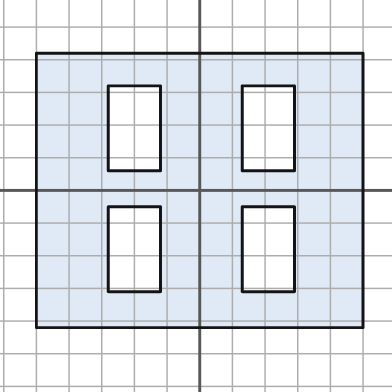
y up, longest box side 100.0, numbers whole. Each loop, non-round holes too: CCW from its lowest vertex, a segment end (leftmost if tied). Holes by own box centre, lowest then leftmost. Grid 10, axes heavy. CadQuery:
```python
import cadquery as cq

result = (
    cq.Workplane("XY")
    .moveTo(-50.0, -42.0)
    .lineTo(50.0, -42.0)
    .lineTo(50.0, 42.0)
    .lineTo(-50.0, 42.0)
    .close()
    .moveTo(-28.0, -31.0)
    .lineTo(-12.0, -31.0)
    .lineTo(-12.0, -5.0)
    .lineTo(-28.0, -5.0)
    .close()
    .moveTo(13.0, -31.0)
    .lineTo(29.0, -31.0)
    .lineTo(29.0, -5.0)
    .lineTo(13.0, -5.0)
    .close()
    .moveTo(-28.0, 6.0)
    .lineTo(-12.0, 6.0)
    .lineTo(-12.0, 32.0)
    .lineTo(-28.0, 32.0)
    .close()
    .moveTo(13.0, 6.0)
    .lineTo(29.0, 6.0)
    .lineTo(29.0, 32.0)
    .lineTo(13.0, 32.0)
    .close()
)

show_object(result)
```